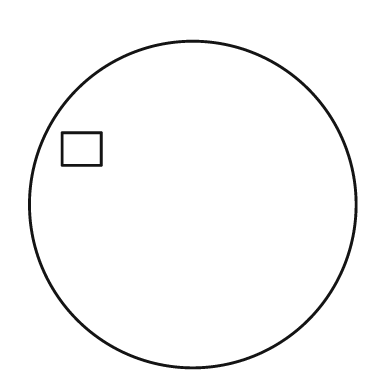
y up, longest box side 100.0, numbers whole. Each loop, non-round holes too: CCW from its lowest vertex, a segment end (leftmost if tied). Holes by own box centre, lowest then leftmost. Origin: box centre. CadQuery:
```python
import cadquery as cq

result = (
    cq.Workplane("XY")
    .moveTo(0.0, 0.0)
    .circle(50.0)
    .moveTo(-40.0, 12.0)
    .lineTo(-28.0, 12.0)
    .lineTo(-28.0, 22.0)
    .lineTo(-40.0, 22.0)
    .close()
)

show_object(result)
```